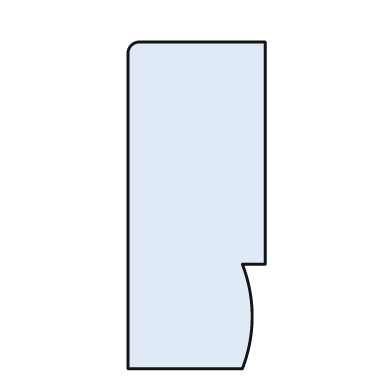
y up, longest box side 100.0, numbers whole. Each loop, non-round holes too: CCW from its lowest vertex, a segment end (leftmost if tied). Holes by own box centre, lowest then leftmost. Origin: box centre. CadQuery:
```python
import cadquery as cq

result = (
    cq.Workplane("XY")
    .moveTo(-21.0, -50.0)
    .lineTo(14.0, -50.0)
    .threePointArc((17.0, -34.0), (14.0, -18.0))
    .lineTo(21.0, -18.0)
    .lineTo(21.0, 50.0)
    .lineTo(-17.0, 50.0)
    .threePointArc((-20.0, 49.0), (-21.0, 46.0))
    .close()
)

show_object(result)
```